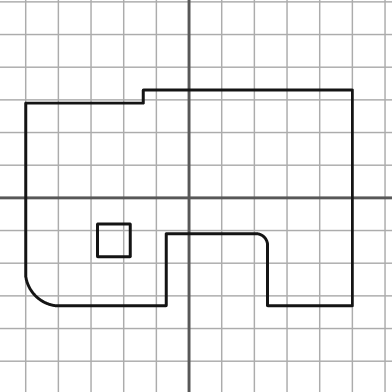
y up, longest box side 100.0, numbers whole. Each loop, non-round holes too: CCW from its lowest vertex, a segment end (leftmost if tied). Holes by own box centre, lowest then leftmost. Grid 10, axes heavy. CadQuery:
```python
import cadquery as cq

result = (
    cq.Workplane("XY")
    .moveTo(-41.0, -33.0)
    .lineTo(-7.0, -33.0)
    .lineTo(-7.0, -11.0)
    .lineTo(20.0, -11.0)
    .threePointArc((23.0, -12.0), (24.0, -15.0))
    .lineTo(24.0, -33.0)
    .lineTo(50.0, -33.0)
    .lineTo(50.0, 33.0)
    .lineTo(-14.0, 33.0)
    .lineTo(-14.0, 29.0)
    .lineTo(-50.0, 29.0)
    .lineTo(-50.0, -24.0)
    .threePointArc((-47.0, -30.0), (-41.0, -33.0))
    .close()
    .moveTo(-28.0, -18.0)
    .lineTo(-18.0, -18.0)
    .lineTo(-18.0, -8.0)
    .lineTo(-28.0, -8.0)
    .close()
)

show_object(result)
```